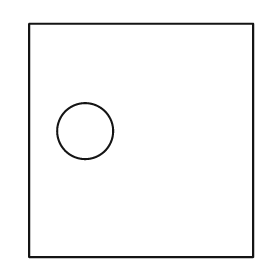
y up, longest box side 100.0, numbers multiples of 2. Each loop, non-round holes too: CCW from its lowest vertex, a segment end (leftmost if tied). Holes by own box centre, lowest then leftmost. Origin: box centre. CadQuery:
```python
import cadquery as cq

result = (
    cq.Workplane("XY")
    .moveTo(-48.0, -50.0)
    .lineTo(48.0, -50.0)
    .lineTo(48.0, 50.0)
    .lineTo(-48.0, 50.0)
    .close()
    .moveTo(-24.0, 4.0)
    .circle(12.0)
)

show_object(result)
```